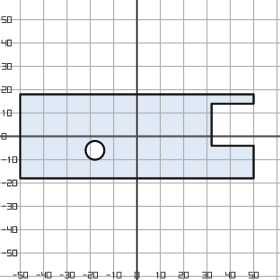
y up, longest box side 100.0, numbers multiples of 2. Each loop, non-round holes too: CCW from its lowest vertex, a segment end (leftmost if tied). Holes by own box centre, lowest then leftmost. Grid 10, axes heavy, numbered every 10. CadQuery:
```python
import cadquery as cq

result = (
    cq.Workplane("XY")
    .moveTo(-50.0, -18.0)
    .lineTo(50.0, -18.0)
    .lineTo(50.0, -4.0)
    .lineTo(32.0, -4.0)
    .lineTo(32.0, 14.0)
    .lineTo(50.0, 14.0)
    .lineTo(50.0, 18.0)
    .lineTo(-50.0, 18.0)
    .close()
    .moveTo(-18.0, -6.0)
    .circle(4.0)
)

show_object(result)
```